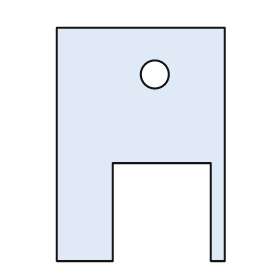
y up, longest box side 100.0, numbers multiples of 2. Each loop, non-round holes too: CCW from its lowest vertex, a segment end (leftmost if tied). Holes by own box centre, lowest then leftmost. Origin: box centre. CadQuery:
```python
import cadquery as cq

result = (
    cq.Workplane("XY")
    .moveTo(-36.0, -50.0)
    .lineTo(-12.0, -50.0)
    .lineTo(-12.0, -8.0)
    .lineTo(30.0, -8.0)
    .lineTo(30.0, -50.0)
    .lineTo(36.0, -50.0)
    .lineTo(36.0, 50.0)
    .lineTo(-36.0, 50.0)
    .close()
    .moveTo(6.0, 30.0)
    .circle(6.0)
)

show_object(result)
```